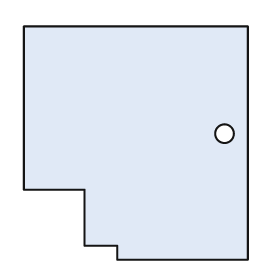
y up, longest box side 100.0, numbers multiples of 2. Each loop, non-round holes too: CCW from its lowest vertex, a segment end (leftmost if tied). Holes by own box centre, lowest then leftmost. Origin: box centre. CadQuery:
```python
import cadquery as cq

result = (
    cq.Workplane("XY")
    .moveTo(-8.0, -50.0)
    .lineTo(48.0, -50.0)
    .lineTo(48.0, 50.0)
    .lineTo(-48.0, 50.0)
    .lineTo(-48.0, -20.0)
    .lineTo(-22.0, -20.0)
    .lineTo(-22.0, -44.0)
    .lineTo(-8.0, -44.0)
    .close()
    .moveTo(38.0, 4.0)
    .circle(4.0)
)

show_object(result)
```